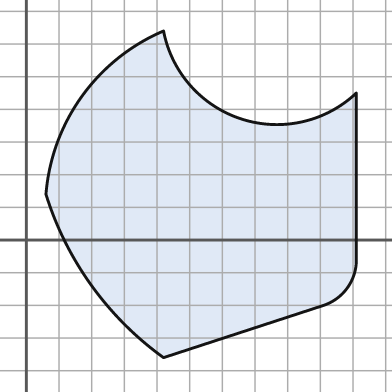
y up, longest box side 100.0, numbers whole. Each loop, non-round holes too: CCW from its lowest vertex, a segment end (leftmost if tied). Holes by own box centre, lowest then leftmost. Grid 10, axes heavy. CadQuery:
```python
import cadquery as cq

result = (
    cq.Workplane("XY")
    .moveTo(42.0, -36.0)
    .lineTo(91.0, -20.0)
    .threePointArc((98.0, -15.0), (101.0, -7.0))
    .lineTo(101.0, 45.0)
    .threePointArc((66.0, 37.0), (42.0, 64.0))
    .threePointArc((17.0, 44.0), (6.0, 14.0))
    .threePointArc((20.0, -14.0), (42.0, -36.0))
    .close()
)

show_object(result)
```